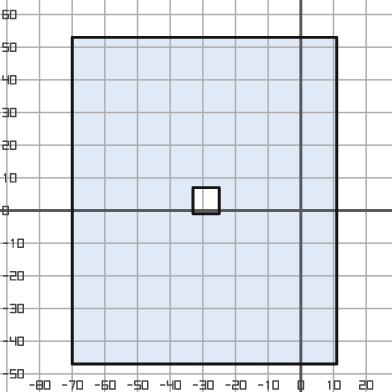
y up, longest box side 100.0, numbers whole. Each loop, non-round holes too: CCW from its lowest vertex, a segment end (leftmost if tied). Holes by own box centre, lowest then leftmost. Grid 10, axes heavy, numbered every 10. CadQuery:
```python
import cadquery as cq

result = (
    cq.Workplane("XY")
    .moveTo(-70.0, -47.0)
    .lineTo(11.0, -47.0)
    .lineTo(11.0, 53.0)
    .lineTo(-70.0, 53.0)
    .close()
    .moveTo(-33.0, -1.0)
    .lineTo(-25.0, -1.0)
    .lineTo(-25.0, 7.0)
    .lineTo(-33.0, 7.0)
    .close()
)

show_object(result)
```